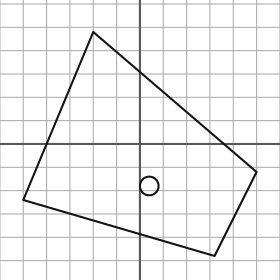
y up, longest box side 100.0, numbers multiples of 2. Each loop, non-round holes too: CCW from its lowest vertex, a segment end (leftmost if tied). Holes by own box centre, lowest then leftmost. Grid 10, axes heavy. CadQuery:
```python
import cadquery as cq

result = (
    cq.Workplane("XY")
    .moveTo(32.0, -48.0)
    .lineTo(50.0, -12.0)
    .lineTo(-20.0, 48.0)
    .lineTo(-50.0, -24.0)
    .close()
    .moveTo(4.0, -18.0)
    .circle(4.0)
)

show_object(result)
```